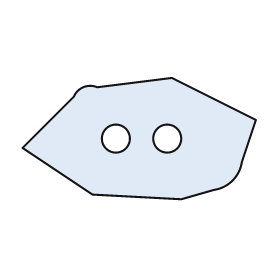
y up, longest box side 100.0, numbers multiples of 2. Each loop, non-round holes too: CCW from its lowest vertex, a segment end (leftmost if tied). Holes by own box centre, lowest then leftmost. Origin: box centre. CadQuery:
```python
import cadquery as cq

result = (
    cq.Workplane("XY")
    .moveTo(18.0, -26.0)
    .lineTo(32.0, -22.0)
    .threePointArc((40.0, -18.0), (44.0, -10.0))
    .lineTo(50.0, 8.0)
    .lineTo(14.0, 26.0)
    .lineTo(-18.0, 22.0)
    .threePointArc((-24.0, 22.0), (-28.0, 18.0))
    .lineTo(-50.0, -4.0)
    .lineTo(-20.0, -24.0)
    .close()
    .moveTo(-10.0, 0.0)
    .circle(6.0)
    .moveTo(12.0, 0.0)
    .circle(6.0)
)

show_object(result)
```